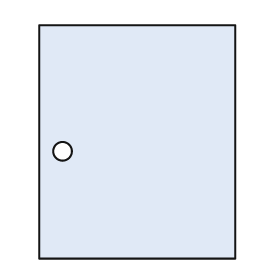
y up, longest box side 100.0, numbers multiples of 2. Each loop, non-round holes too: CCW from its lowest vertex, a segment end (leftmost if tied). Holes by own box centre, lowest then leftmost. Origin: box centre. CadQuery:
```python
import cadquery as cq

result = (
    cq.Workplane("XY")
    .moveTo(-42.0, -50.0)
    .lineTo(42.0, -50.0)
    .lineTo(42.0, 50.0)
    .lineTo(-42.0, 50.0)
    .close()
    .moveTo(-32.0, -4.0)
    .circle(4.0)
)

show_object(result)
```